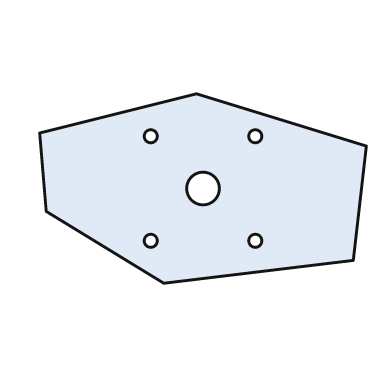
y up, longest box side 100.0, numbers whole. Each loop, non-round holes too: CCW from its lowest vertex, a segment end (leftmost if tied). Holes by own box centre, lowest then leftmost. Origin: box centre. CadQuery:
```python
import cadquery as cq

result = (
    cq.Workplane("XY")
    .moveTo(-12.0, -29.0)
    .lineTo(46.0, -22.0)
    .lineTo(50.0, 13.0)
    .lineTo(-2.0, 29.0)
    .lineTo(-50.0, 17.0)
    .lineTo(-48.0, -7.0)
    .close()
    .moveTo(-16.0, -16.0)
    .circle(2.0)
    .moveTo(16.0, -16.0)
    .circle(2.0)
    .moveTo(0.0, 0.0)
    .circle(5.0)
    .moveTo(-16.0, 16.0)
    .circle(2.0)
    .moveTo(16.0, 16.0)
    .circle(2.0)
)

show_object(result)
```